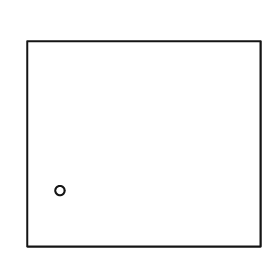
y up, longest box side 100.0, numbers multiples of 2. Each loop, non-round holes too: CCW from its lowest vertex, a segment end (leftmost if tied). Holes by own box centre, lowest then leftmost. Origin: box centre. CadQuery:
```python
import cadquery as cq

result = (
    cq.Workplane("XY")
    .moveTo(-50.0, -44.0)
    .lineTo(50.0, -44.0)
    .lineTo(50.0, 44.0)
    .lineTo(-50.0, 44.0)
    .close()
    .moveTo(-36.0, -20.0)
    .circle(2.0)
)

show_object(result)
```